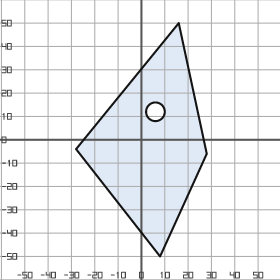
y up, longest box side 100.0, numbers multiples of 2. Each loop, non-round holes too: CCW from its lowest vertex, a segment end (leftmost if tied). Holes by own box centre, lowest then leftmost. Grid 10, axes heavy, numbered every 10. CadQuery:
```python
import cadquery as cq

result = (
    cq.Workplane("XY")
    .moveTo(8.0, -50.0)
    .lineTo(28.0, -6.0)
    .lineTo(16.0, 50.0)
    .lineTo(-28.0, -4.0)
    .close()
    .moveTo(6.0, 12.0)
    .circle(4.0)
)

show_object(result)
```